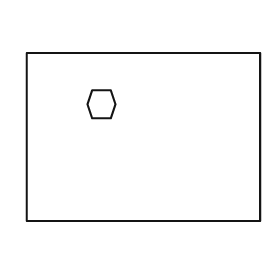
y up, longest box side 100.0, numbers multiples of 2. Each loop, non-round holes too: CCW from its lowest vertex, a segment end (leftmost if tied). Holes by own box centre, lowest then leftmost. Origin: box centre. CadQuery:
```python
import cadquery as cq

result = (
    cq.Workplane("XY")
    .moveTo(-50.0, -36.0)
    .lineTo(50.0, -36.0)
    .lineTo(50.0, 36.0)
    .lineTo(-50.0, 36.0)
    .close()
    .moveTo(-22.0, 8.0)
    .lineTo(-14.0, 8.0)
    .lineTo(-12.0, 14.0)
    .lineTo(-14.0, 20.0)
    .lineTo(-22.0, 20.0)
    .lineTo(-24.0, 14.0)
    .close()
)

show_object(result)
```